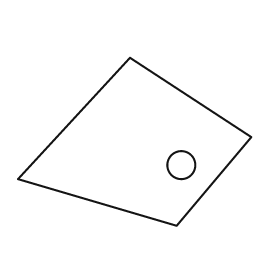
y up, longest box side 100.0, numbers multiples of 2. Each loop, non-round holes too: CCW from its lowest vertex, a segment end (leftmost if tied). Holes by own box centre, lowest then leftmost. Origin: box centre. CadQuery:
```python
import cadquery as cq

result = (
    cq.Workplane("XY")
    .moveTo(18.0, -36.0)
    .lineTo(50.0, 2.0)
    .lineTo(-2.0, 36.0)
    .lineTo(-50.0, -16.0)
    .close()
    .moveTo(20.0, -10.0)
    .circle(6.0)
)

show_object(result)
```